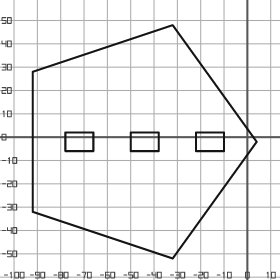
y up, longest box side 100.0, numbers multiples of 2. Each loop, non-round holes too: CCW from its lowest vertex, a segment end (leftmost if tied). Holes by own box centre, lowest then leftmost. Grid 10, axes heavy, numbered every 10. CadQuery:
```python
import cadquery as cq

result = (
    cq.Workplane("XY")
    .moveTo(-32.0, -52.0)
    .lineTo(4.0, -2.0)
    .lineTo(-32.0, 48.0)
    .lineTo(-92.0, 28.0)
    .lineTo(-92.0, -32.0)
    .close()
    .moveTo(-78.0, -6.0)
    .lineTo(-66.0, -6.0)
    .lineTo(-66.0, 2.0)
    .lineTo(-78.0, 2.0)
    .close()
    .moveTo(-50.0, -6.0)
    .lineTo(-38.0, -6.0)
    .lineTo(-38.0, 2.0)
    .lineTo(-50.0, 2.0)
    .close()
    .moveTo(-22.0, -6.0)
    .lineTo(-10.0, -6.0)
    .lineTo(-10.0, 2.0)
    .lineTo(-22.0, 2.0)
    .close()
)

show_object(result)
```